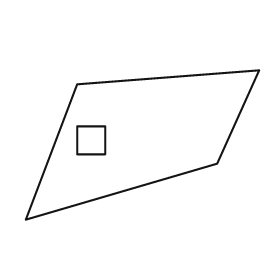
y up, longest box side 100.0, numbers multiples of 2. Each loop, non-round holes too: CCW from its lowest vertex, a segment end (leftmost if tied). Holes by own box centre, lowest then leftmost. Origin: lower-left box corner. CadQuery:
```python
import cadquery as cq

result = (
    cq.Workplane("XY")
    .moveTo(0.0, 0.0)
    .lineTo(82.0, 24.0)
    .lineTo(100.0, 64.0)
    .lineTo(22.0, 58.0)
    .close()
    .moveTo(22.0, 28.0)
    .lineTo(34.0, 28.0)
    .lineTo(34.0, 40.0)
    .lineTo(22.0, 40.0)
    .close()
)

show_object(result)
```